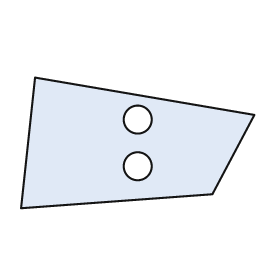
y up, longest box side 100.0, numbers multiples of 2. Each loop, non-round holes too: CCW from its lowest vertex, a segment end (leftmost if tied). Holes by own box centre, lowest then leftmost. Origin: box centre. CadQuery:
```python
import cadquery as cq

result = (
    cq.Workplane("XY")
    .moveTo(-50.0, -28.0)
    .lineTo(32.0, -22.0)
    .lineTo(50.0, 12.0)
    .lineTo(-44.0, 28.0)
    .close()
    .moveTo(0.0, -10.0)
    .circle(6.0)
    .moveTo(0.0, 10.0)
    .circle(6.0)
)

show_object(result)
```